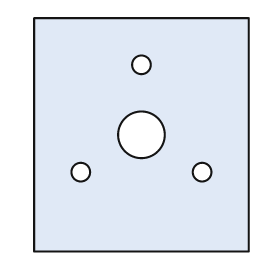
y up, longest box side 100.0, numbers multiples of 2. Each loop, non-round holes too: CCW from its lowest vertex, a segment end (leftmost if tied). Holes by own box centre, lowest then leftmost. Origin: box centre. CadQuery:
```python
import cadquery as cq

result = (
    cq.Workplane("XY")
    .moveTo(-46.0, -50.0)
    .lineTo(46.0, -50.0)
    .lineTo(46.0, 50.0)
    .lineTo(-46.0, 50.0)
    .close()
    .moveTo(-26.0, -16.0)
    .circle(4.0)
    .moveTo(26.0, -16.0)
    .circle(4.0)
    .moveTo(0.0, 0.0)
    .circle(10.0)
    .moveTo(0.0, 30.0)
    .circle(4.0)
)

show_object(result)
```